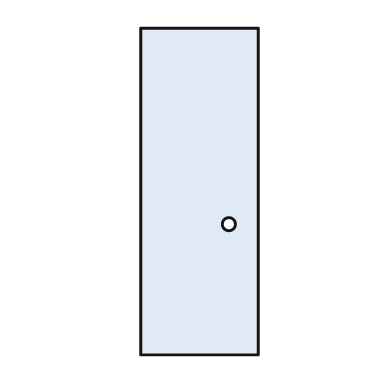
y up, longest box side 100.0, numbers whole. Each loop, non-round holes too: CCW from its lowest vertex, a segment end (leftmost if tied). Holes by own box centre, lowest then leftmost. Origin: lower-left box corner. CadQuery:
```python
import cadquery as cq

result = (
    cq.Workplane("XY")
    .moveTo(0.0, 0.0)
    .lineTo(36.0, 0.0)
    .lineTo(36.0, 100.0)
    .lineTo(0.0, 100.0)
    .close()
    .moveTo(27.0, 40.0)
    .circle(2.0)
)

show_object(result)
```